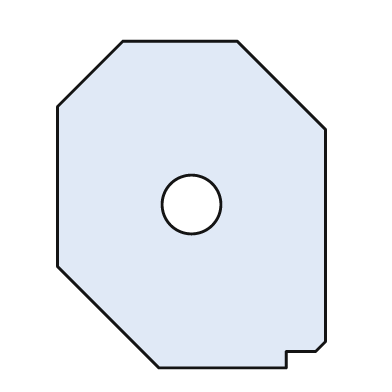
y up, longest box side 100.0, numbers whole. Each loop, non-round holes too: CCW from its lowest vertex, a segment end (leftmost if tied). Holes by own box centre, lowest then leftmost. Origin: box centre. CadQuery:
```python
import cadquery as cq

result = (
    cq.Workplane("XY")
    .moveTo(-10.0, -50.0)
    .lineTo(29.0, -50.0)
    .lineTo(29.0, -45.0)
    .lineTo(38.0, -45.0)
    .lineTo(41.0, -42.0)
    .lineTo(41.0, 23.0)
    .lineTo(14.0, 50.0)
    .lineTo(-21.0, 50.0)
    .lineTo(-41.0, 30.0)
    .lineTo(-41.0, -19.0)
    .close()
    .moveTo(0.0, 0.0)
    .circle(9.0)
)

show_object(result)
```